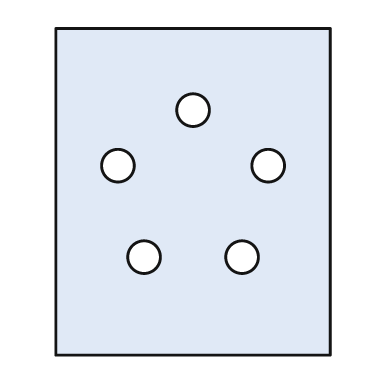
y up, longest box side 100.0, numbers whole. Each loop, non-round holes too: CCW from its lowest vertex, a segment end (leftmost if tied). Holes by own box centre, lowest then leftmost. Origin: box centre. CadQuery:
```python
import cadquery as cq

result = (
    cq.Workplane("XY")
    .moveTo(-42.0, -50.0)
    .lineTo(42.0, -50.0)
    .lineTo(42.0, 50.0)
    .lineTo(-42.0, 50.0)
    .close()
    .moveTo(-15.0, -20.0)
    .circle(5.0)
    .moveTo(15.0, -20.0)
    .circle(5.0)
    .moveTo(-23.0, 8.0)
    .circle(5.0)
    .moveTo(23.0, 8.0)
    .circle(5.0)
    .moveTo(0.0, 25.0)
    .circle(5.0)
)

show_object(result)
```